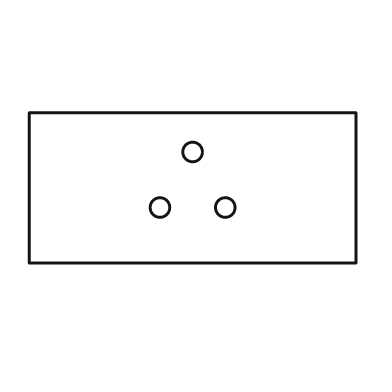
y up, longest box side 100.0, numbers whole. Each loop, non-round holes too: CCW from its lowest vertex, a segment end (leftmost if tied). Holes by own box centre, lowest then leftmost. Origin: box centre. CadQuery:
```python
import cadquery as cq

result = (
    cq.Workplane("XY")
    .moveTo(-50.0, -23.0)
    .lineTo(50.0, -23.0)
    .lineTo(50.0, 23.0)
    .lineTo(-50.0, 23.0)
    .close()
    .moveTo(-10.0, -6.0)
    .circle(3.0)
    .moveTo(10.0, -6.0)
    .circle(3.0)
    .moveTo(0.0, 11.0)
    .circle(3.0)
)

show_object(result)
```